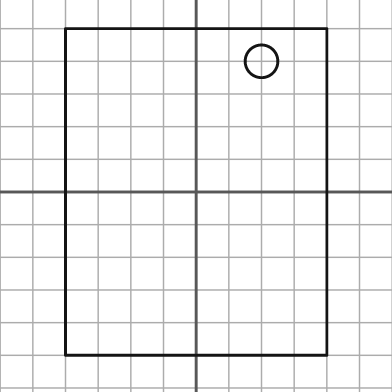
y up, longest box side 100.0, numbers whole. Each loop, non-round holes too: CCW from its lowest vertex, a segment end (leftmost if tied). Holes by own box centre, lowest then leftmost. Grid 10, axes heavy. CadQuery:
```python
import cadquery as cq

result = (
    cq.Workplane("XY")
    .moveTo(-40.0, -50.0)
    .lineTo(40.0, -50.0)
    .lineTo(40.0, 50.0)
    .lineTo(-40.0, 50.0)
    .close()
    .moveTo(20.0, 40.0)
    .circle(5.0)
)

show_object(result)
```